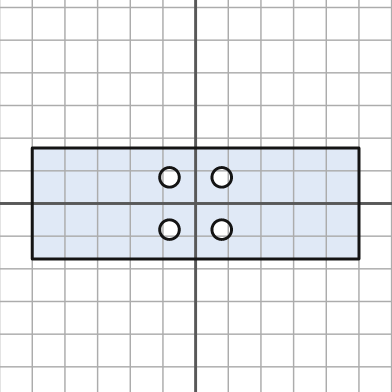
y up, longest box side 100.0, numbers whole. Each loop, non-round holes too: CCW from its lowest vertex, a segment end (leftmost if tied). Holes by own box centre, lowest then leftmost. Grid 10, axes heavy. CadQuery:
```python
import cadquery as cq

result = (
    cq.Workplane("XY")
    .moveTo(-50.0, -17.0)
    .lineTo(50.0, -17.0)
    .lineTo(50.0, 17.0)
    .lineTo(-50.0, 17.0)
    .close()
    .moveTo(-8.0, -8.0)
    .circle(3.0)
    .moveTo(8.0, -8.0)
    .circle(3.0)
    .moveTo(-8.0, 8.0)
    .circle(3.0)
    .moveTo(8.0, 8.0)
    .circle(3.0)
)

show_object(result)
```